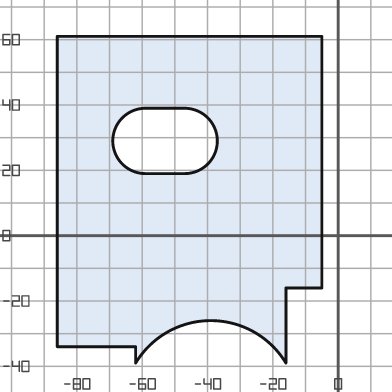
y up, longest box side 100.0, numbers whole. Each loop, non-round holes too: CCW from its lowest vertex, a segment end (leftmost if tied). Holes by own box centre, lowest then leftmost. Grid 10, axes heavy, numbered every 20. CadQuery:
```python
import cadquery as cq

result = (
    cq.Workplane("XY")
    .moveTo(-62.0, -39.0)
    .threePointArc((-39.0, -26.0), (-16.0, -39.0))
    .lineTo(-16.0, -16.0)
    .lineTo(-5.0, -16.0)
    .lineTo(-5.0, 61.0)
    .lineTo(-86.0, 61.0)
    .lineTo(-86.0, -34.0)
    .lineTo(-62.0, -34.0)
    .close()
    .moveTo(-59.0, 19.0)
    .lineTo(-47.0, 19.0)
    .threePointArc((-37.0, 29.0), (-47.0, 39.0))
    .lineTo(-59.0, 39.0)
    .threePointArc((-69.0, 29.0), (-59.0, 19.0))
    .close()
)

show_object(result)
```